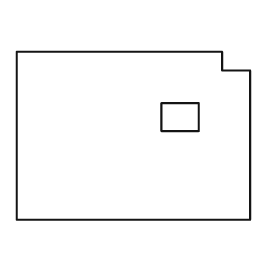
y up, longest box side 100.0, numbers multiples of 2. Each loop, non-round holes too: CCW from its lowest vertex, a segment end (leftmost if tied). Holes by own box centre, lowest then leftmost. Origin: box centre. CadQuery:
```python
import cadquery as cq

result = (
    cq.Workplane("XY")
    .moveTo(-50.0, -36.0)
    .lineTo(50.0, -36.0)
    .lineTo(50.0, 28.0)
    .lineTo(38.0, 28.0)
    .lineTo(38.0, 36.0)
    .lineTo(-50.0, 36.0)
    .close()
    .moveTo(12.0, 2.0)
    .lineTo(28.0, 2.0)
    .lineTo(28.0, 14.0)
    .lineTo(12.0, 14.0)
    .close()
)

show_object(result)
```